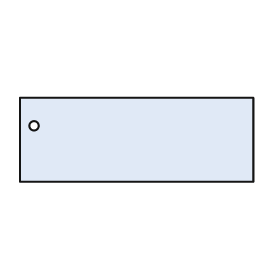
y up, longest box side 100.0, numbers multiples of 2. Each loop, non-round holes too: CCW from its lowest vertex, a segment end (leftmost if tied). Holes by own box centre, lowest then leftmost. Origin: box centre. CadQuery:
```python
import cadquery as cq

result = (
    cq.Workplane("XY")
    .moveTo(-50.0, -18.0)
    .lineTo(50.0, -18.0)
    .lineTo(50.0, 18.0)
    .lineTo(-50.0, 18.0)
    .close()
    .moveTo(-44.0, 6.0)
    .circle(2.0)
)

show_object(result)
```